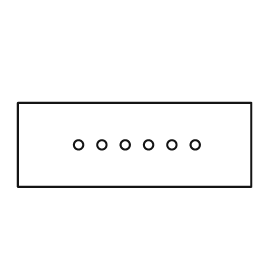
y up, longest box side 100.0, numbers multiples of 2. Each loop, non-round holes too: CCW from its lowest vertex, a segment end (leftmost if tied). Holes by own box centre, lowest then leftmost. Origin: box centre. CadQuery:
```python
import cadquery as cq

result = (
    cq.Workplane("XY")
    .moveTo(-50.0, -18.0)
    .lineTo(50.0, -18.0)
    .lineTo(50.0, 18.0)
    .lineTo(-50.0, 18.0)
    .close()
    .moveTo(-24.0, 0.0)
    .circle(2.0)
    .moveTo(-14.0, 0.0)
    .circle(2.0)
    .moveTo(-4.0, 0.0)
    .circle(2.0)
    .moveTo(6.0, 0.0)
    .circle(2.0)
    .moveTo(16.0, 0.0)
    .circle(2.0)
    .moveTo(26.0, 0.0)
    .circle(2.0)
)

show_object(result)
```